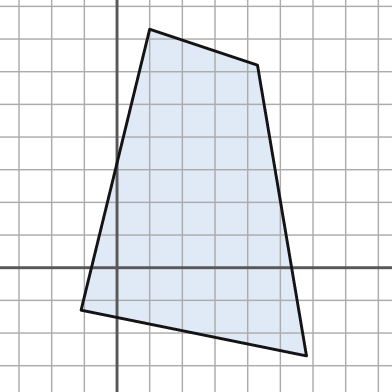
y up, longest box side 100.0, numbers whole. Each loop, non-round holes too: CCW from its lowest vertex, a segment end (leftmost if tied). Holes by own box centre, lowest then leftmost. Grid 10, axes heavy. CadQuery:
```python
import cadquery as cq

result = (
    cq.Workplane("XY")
    .moveTo(58.0, -27.0)
    .lineTo(43.0, 62.0)
    .lineTo(10.0, 73.0)
    .lineTo(-11.0, -13.0)
    .close()
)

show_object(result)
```